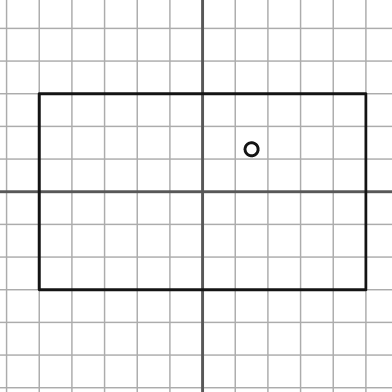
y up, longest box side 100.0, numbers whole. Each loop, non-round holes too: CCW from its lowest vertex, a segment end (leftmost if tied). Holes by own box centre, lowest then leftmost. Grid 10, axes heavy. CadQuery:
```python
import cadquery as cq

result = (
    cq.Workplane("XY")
    .moveTo(-50.0, -30.0)
    .lineTo(50.0, -30.0)
    .lineTo(50.0, 30.0)
    .lineTo(-50.0, 30.0)
    .close()
    .moveTo(15.0, 13.0)
    .circle(2.0)
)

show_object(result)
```